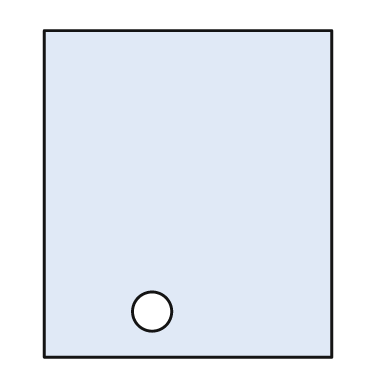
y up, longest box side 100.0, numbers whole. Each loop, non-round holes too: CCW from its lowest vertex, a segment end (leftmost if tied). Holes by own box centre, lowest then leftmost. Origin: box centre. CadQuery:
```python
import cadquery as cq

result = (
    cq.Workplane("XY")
    .moveTo(-44.0, -50.0)
    .lineTo(44.0, -50.0)
    .lineTo(44.0, 50.0)
    .lineTo(-44.0, 50.0)
    .close()
    .moveTo(-11.0, -36.0)
    .circle(6.0)
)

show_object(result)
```